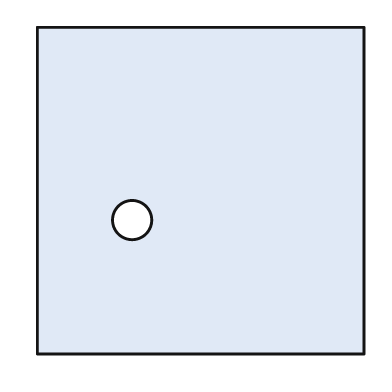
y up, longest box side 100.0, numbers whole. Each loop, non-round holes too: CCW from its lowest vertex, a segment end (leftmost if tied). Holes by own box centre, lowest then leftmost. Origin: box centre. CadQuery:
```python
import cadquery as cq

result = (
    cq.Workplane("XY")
    .moveTo(-50.0, -50.0)
    .lineTo(50.0, -50.0)
    .lineTo(50.0, 50.0)
    .lineTo(-50.0, 50.0)
    .close()
    .moveTo(-21.0, -9.0)
    .circle(6.0)
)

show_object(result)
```